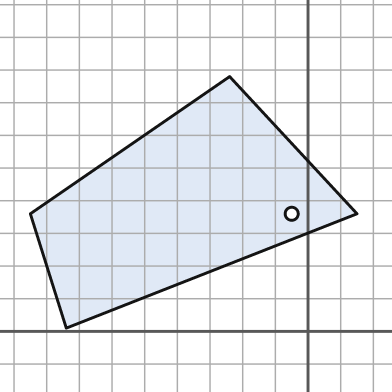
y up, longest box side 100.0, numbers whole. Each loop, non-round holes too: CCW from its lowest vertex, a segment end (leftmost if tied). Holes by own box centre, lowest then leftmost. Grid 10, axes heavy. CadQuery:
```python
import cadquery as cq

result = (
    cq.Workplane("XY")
    .moveTo(-74.0, 1.0)
    .lineTo(15.0, 36.0)
    .lineTo(-24.0, 78.0)
    .lineTo(-85.0, 36.0)
    .close()
    .moveTo(-5.0, 36.0)
    .circle(2.0)
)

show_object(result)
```